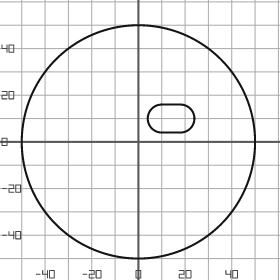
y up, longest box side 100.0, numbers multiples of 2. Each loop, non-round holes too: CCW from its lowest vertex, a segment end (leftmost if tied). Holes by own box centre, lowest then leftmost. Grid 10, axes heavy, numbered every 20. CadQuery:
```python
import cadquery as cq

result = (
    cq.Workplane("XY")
    .moveTo(0.0, 0.0)
    .circle(50.0)
    .moveTo(10.0, 4.0)
    .lineTo(18.0, 4.0)
    .threePointArc((24.0, 10.0), (18.0, 16.0))
    .lineTo(10.0, 16.0)
    .threePointArc((4.0, 10.0), (10.0, 4.0))
    .close()
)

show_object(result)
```